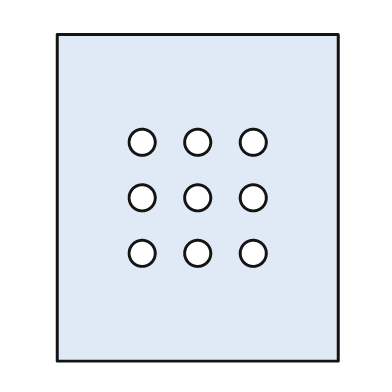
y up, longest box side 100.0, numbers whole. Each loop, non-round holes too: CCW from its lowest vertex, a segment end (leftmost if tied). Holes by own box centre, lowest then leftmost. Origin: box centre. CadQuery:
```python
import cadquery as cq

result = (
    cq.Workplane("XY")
    .moveTo(-43.0, -50.0)
    .lineTo(43.0, -50.0)
    .lineTo(43.0, 50.0)
    .lineTo(-43.0, 50.0)
    .close()
    .moveTo(-17.0, -17.0)
    .circle(4.0)
    .moveTo(0.0, -17.0)
    .circle(4.0)
    .moveTo(17.0, -17.0)
    .circle(4.0)
    .moveTo(-17.0, 0.0)
    .circle(4.0)
    .moveTo(0.0, 0.0)
    .circle(4.0)
    .moveTo(17.0, 0.0)
    .circle(4.0)
    .moveTo(-17.0, 17.0)
    .circle(4.0)
    .moveTo(0.0, 17.0)
    .circle(4.0)
    .moveTo(17.0, 17.0)
    .circle(4.0)
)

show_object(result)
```